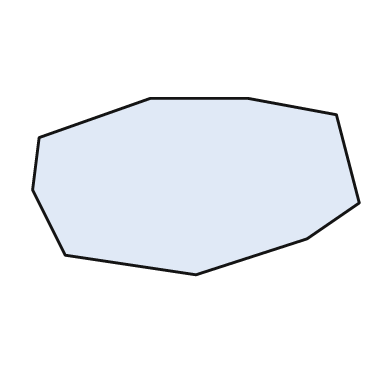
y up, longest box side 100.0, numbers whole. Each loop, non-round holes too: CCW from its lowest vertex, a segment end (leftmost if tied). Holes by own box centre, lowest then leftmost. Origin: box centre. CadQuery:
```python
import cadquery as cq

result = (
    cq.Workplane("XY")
    .moveTo(0.0, -27.0)
    .lineTo(34.0, -16.0)
    .lineTo(50.0, -5.0)
    .lineTo(43.0, 22.0)
    .lineTo(16.0, 27.0)
    .lineTo(-14.0, 27.0)
    .lineTo(-48.0, 15.0)
    .lineTo(-50.0, -1.0)
    .lineTo(-40.0, -21.0)
    .close()
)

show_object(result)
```